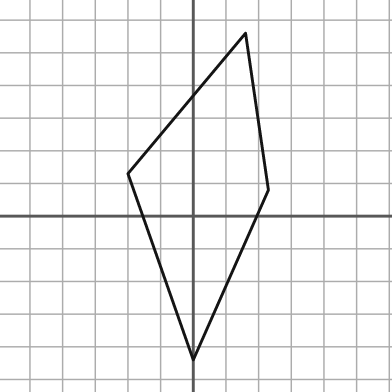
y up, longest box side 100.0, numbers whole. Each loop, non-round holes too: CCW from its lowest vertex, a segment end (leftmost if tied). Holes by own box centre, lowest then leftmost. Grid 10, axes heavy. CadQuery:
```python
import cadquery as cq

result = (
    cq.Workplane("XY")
    .moveTo(0.0, -44.0)
    .lineTo(23.0, 8.0)
    .lineTo(16.0, 56.0)
    .lineTo(-20.0, 13.0)
    .close()
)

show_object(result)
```